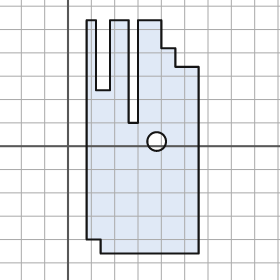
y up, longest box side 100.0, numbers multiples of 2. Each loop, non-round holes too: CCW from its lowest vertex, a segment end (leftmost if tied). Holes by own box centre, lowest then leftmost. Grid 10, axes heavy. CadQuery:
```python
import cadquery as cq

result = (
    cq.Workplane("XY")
    .moveTo(14.0, -46.0)
    .lineTo(56.0, -46.0)
    .lineTo(56.0, 34.0)
    .lineTo(46.0, 34.0)
    .lineTo(46.0, 42.0)
    .lineTo(40.0, 42.0)
    .lineTo(40.0, 54.0)
    .lineTo(30.0, 54.0)
    .lineTo(30.0, 10.0)
    .lineTo(26.0, 10.0)
    .lineTo(26.0, 54.0)
    .lineTo(18.0, 54.0)
    .lineTo(18.0, 24.0)
    .lineTo(12.0, 24.0)
    .lineTo(12.0, 54.0)
    .lineTo(8.0, 54.0)
    .lineTo(8.0, -40.0)
    .lineTo(14.0, -40.0)
    .close()
    .moveTo(38.0, 2.0)
    .circle(4.0)
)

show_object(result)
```